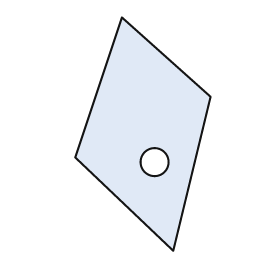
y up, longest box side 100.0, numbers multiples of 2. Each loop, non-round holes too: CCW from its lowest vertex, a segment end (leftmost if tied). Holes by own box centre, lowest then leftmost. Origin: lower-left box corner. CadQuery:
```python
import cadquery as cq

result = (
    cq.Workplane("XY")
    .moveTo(42.0, 0.0)
    .lineTo(58.0, 66.0)
    .lineTo(20.0, 100.0)
    .lineTo(0.0, 40.0)
    .close()
    .moveTo(34.0, 38.0)
    .circle(6.0)
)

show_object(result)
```